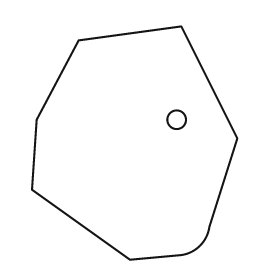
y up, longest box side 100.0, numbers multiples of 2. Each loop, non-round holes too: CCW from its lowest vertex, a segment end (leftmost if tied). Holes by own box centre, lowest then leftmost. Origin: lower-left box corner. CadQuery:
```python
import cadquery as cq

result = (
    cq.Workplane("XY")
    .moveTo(42.0, 0.0)
    .lineTo(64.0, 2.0)
    .threePointArc((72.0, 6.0), (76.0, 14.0))
    .lineTo(88.0, 52.0)
    .lineTo(64.0, 100.0)
    .lineTo(20.0, 94.0)
    .lineTo(2.0, 60.0)
    .lineTo(0.0, 30.0)
    .close()
    .moveTo(62.0, 60.0)
    .circle(4.0)
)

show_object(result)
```